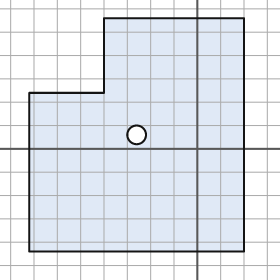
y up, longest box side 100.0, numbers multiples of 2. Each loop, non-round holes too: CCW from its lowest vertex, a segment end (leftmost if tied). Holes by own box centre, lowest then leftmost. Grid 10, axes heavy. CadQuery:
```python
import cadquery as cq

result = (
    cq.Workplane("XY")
    .moveTo(-72.0, -44.0)
    .lineTo(20.0, -44.0)
    .lineTo(20.0, 56.0)
    .lineTo(-40.0, 56.0)
    .lineTo(-40.0, 24.0)
    .lineTo(-72.0, 24.0)
    .close()
    .moveTo(-26.0, 6.0)
    .circle(4.0)
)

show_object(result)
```